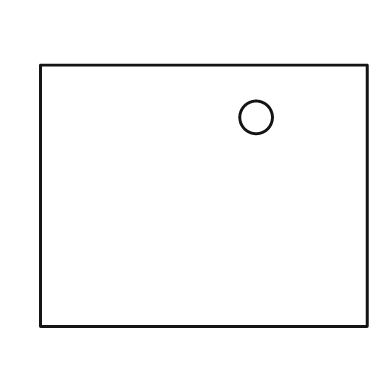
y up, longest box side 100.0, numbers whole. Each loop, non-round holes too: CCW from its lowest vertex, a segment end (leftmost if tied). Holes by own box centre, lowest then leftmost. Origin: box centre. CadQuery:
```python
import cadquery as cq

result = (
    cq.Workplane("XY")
    .moveTo(-50.0, -40.0)
    .lineTo(50.0, -40.0)
    .lineTo(50.0, 40.0)
    .lineTo(-50.0, 40.0)
    .close()
    .moveTo(16.0, 24.0)
    .circle(5.0)
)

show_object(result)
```